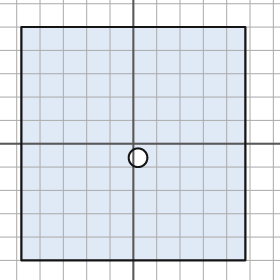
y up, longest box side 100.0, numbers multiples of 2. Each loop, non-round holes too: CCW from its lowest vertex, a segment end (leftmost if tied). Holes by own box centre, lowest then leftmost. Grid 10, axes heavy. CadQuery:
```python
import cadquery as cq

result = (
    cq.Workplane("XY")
    .moveTo(-48.0, -50.0)
    .lineTo(48.0, -50.0)
    .lineTo(48.0, 50.0)
    .lineTo(-48.0, 50.0)
    .close()
    .moveTo(2.0, -6.0)
    .circle(4.0)
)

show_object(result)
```